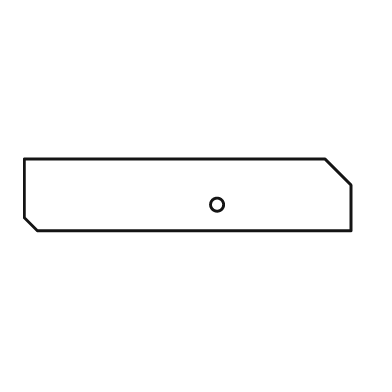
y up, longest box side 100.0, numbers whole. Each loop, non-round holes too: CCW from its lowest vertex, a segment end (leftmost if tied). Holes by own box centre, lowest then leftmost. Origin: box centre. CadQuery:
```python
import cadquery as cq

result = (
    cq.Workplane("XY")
    .moveTo(-46.0, -11.0)
    .lineTo(50.0, -11.0)
    .lineTo(50.0, 3.0)
    .lineTo(42.0, 11.0)
    .lineTo(-50.0, 11.0)
    .lineTo(-50.0, -7.0)
    .close()
    .moveTo(9.0, -3.0)
    .circle(2.0)
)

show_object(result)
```